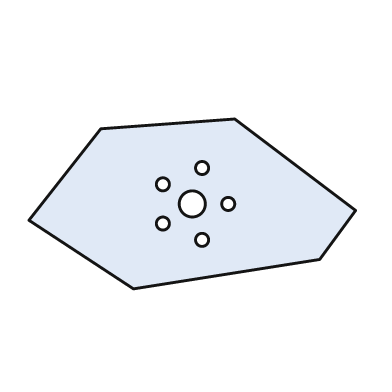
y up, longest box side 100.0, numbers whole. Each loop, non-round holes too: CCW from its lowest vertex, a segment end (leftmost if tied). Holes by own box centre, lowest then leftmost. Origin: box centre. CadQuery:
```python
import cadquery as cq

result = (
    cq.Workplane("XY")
    .moveTo(-18.0, -26.0)
    .lineTo(39.0, -17.0)
    .lineTo(50.0, -2.0)
    .lineTo(13.0, 26.0)
    .lineTo(-28.0, 23.0)
    .lineTo(-50.0, -5.0)
    .close()
    .moveTo(3.0, -11.0)
    .circle(2.0)
    .moveTo(-9.0, -6.0)
    .circle(2.0)
    .moveTo(0.0, 0.0)
    .circle(4.0)
    .moveTo(11.0, 0.0)
    .circle(2.0)
    .moveTo(-9.0, 6.0)
    .circle(2.0)
    .moveTo(3.0, 11.0)
    .circle(2.0)
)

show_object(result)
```